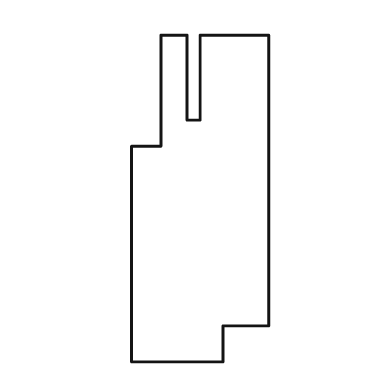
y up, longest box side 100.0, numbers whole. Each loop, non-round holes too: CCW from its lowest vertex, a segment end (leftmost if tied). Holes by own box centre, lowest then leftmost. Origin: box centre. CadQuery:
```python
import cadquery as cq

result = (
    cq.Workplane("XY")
    .moveTo(-21.0, -50.0)
    .lineTo(7.0, -50.0)
    .lineTo(7.0, -39.0)
    .lineTo(21.0, -39.0)
    .lineTo(21.0, 50.0)
    .lineTo(0.0, 50.0)
    .lineTo(0.0, 24.0)
    .lineTo(-4.0, 24.0)
    .lineTo(-4.0, 50.0)
    .lineTo(-12.0, 50.0)
    .lineTo(-12.0, 16.0)
    .lineTo(-21.0, 16.0)
    .close()
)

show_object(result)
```